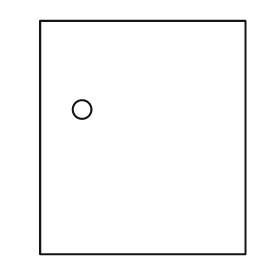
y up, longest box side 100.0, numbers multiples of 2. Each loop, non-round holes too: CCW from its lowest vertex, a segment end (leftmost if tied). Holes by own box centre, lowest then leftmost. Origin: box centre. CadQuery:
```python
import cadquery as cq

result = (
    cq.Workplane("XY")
    .moveTo(-44.0, -50.0)
    .lineTo(44.0, -50.0)
    .lineTo(44.0, 50.0)
    .lineTo(-44.0, 50.0)
    .close()
    .moveTo(-26.0, 12.0)
    .circle(4.0)
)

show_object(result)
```